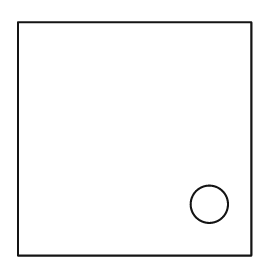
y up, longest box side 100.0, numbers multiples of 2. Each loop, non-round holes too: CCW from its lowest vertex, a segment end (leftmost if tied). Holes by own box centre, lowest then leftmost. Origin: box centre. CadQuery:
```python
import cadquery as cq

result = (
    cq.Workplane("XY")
    .moveTo(-50.0, -50.0)
    .lineTo(50.0, -50.0)
    .lineTo(50.0, 50.0)
    .lineTo(-50.0, 50.0)
    .close()
    .moveTo(32.0, -28.0)
    .circle(8.0)
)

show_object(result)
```